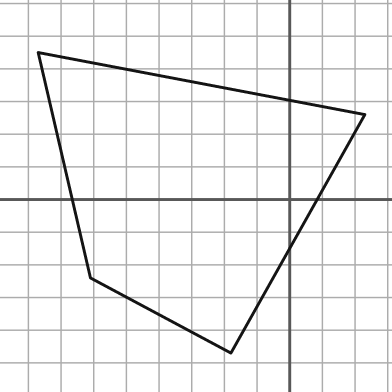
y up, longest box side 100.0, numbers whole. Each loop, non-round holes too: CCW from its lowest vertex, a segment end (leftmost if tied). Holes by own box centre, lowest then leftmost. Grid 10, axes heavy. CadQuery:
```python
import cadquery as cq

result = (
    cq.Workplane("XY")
    .moveTo(-18.0, -47.0)
    .lineTo(23.0, 26.0)
    .lineTo(-77.0, 45.0)
    .lineTo(-61.0, -24.0)
    .close()
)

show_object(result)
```